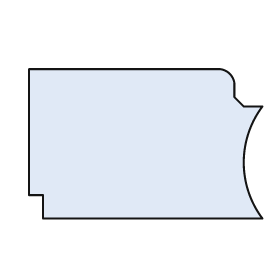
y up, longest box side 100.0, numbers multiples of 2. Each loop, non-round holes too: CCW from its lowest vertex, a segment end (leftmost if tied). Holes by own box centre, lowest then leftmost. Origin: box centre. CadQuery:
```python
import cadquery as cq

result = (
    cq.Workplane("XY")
    .moveTo(-44.0, -32.0)
    .lineTo(50.0, -32.0)
    .threePointArc((42.0, -8.0), (50.0, 16.0))
    .lineTo(42.0, 16.0)
    .lineTo(38.0, 20.0)
    .lineTo(38.0, 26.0)
    .threePointArc((36.0, 30.0), (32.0, 32.0))
    .lineTo(-50.0, 32.0)
    .lineTo(-50.0, -22.0)
    .lineTo(-44.0, -22.0)
    .close()
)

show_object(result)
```